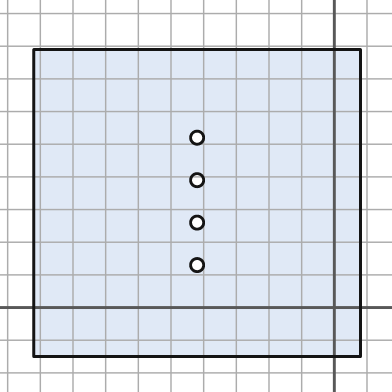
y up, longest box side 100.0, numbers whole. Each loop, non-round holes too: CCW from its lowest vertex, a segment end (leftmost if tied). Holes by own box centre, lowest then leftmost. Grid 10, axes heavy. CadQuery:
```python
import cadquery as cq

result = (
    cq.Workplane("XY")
    .moveTo(-92.0, -15.0)
    .lineTo(8.0, -15.0)
    .lineTo(8.0, 79.0)
    .lineTo(-92.0, 79.0)
    .close()
    .moveTo(-42.0, 13.0)
    .circle(2.0)
    .moveTo(-42.0, 26.0)
    .circle(2.0)
    .moveTo(-42.0, 39.0)
    .circle(2.0)
    .moveTo(-42.0, 52.0)
    .circle(2.0)
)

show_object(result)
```